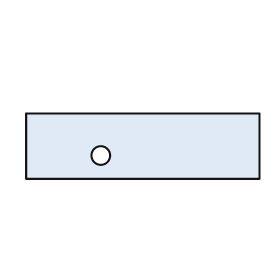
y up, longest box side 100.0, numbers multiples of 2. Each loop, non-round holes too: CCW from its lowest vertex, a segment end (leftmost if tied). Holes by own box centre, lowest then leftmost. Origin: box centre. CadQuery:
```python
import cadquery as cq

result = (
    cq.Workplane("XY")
    .moveTo(-50.0, -14.0)
    .lineTo(50.0, -14.0)
    .lineTo(50.0, 14.0)
    .lineTo(-50.0, 14.0)
    .close()
    .moveTo(-18.0, -4.0)
    .circle(4.0)
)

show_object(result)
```